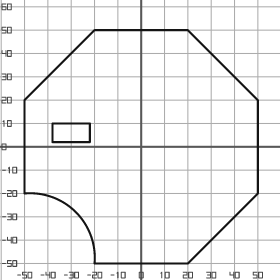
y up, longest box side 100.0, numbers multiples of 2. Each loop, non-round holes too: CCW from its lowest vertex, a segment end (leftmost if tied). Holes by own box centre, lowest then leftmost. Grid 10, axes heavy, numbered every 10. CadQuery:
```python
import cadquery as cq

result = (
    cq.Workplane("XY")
    .moveTo(-20.0, -50.0)
    .lineTo(20.0, -50.0)
    .lineTo(50.0, -20.0)
    .lineTo(50.0, 20.0)
    .lineTo(20.0, 50.0)
    .lineTo(-20.0, 50.0)
    .lineTo(-50.0, 20.0)
    .lineTo(-50.0, -20.0)
    .threePointArc((-28.0, -28.0), (-20.0, -50.0))
    .close()
    .moveTo(-38.0, 2.0)
    .lineTo(-22.0, 2.0)
    .lineTo(-22.0, 10.0)
    .lineTo(-38.0, 10.0)
    .close()
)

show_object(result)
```